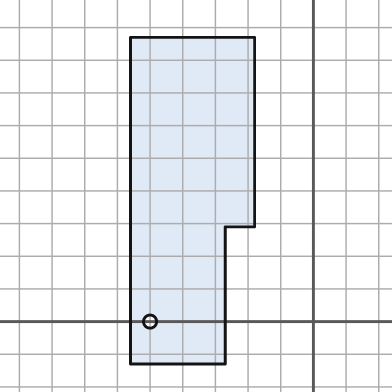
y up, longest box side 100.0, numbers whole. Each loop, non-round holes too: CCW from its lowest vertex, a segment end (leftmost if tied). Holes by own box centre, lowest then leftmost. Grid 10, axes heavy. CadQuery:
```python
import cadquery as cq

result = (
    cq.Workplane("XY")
    .moveTo(-56.0, -13.0)
    .lineTo(-27.0, -13.0)
    .lineTo(-27.0, 29.0)
    .lineTo(-18.0, 29.0)
    .lineTo(-18.0, 87.0)
    .lineTo(-56.0, 87.0)
    .close()
    .moveTo(-50.0, 0.0)
    .circle(2.0)
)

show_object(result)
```